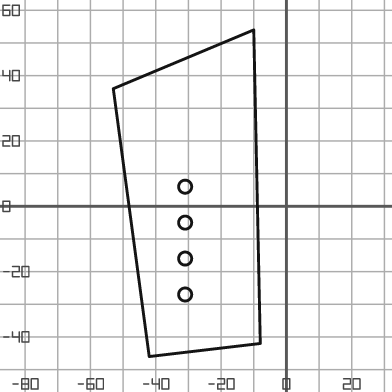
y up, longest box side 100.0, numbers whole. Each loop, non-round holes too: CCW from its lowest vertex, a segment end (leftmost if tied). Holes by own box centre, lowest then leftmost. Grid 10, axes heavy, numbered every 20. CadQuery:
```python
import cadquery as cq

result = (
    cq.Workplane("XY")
    .moveTo(-42.0, -46.0)
    .lineTo(-8.0, -42.0)
    .lineTo(-10.0, 54.0)
    .lineTo(-53.0, 36.0)
    .close()
    .moveTo(-31.0, -27.0)
    .circle(2.0)
    .moveTo(-31.0, -16.0)
    .circle(2.0)
    .moveTo(-31.0, -5.0)
    .circle(2.0)
    .moveTo(-31.0, 6.0)
    .circle(2.0)
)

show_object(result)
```